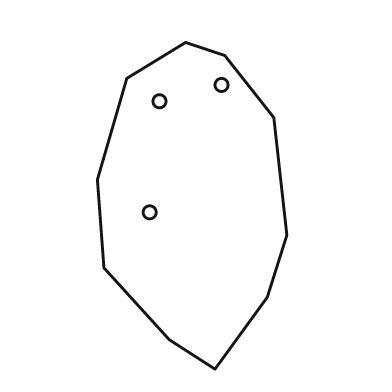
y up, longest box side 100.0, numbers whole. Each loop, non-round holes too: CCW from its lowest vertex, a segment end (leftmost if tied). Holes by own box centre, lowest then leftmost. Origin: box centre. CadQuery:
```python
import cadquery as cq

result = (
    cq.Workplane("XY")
    .moveTo(7.0, -50.0)
    .lineTo(23.0, -28.0)
    .lineTo(29.0, -9.0)
    .lineTo(25.0, 27.0)
    .lineTo(10.0, 46.0)
    .lineTo(-2.0, 50.0)
    .lineTo(-20.0, 39.0)
    .lineTo(-29.0, 8.0)
    .lineTo(-27.0, -19.0)
    .lineTo(-7.0, -41.0)
    .close()
    .moveTo(-13.0, -2.0)
    .circle(2.0)
    .moveTo(-10.0, 32.0)
    .circle(2.0)
    .moveTo(9.0, 37.0)
    .circle(2.0)
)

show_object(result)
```